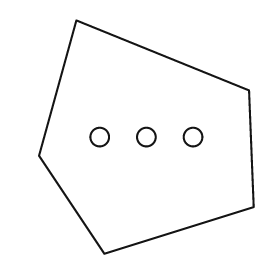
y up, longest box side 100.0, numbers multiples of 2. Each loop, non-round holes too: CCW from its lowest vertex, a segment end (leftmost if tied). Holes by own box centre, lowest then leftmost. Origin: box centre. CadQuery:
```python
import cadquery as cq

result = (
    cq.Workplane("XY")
    .moveTo(-18.0, -50.0)
    .lineTo(46.0, -30.0)
    .lineTo(44.0, 20.0)
    .lineTo(-30.0, 50.0)
    .lineTo(-46.0, -8.0)
    .close()
    .moveTo(-20.0, 0.0)
    .circle(4.0)
    .moveTo(0.0, 0.0)
    .circle(4.0)
    .moveTo(20.0, 0.0)
    .circle(4.0)
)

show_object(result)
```